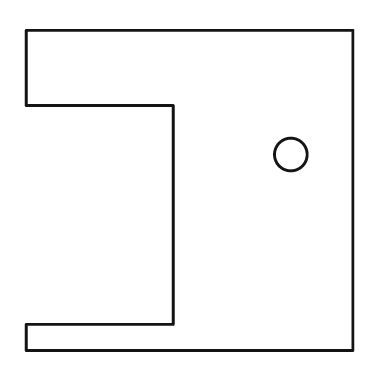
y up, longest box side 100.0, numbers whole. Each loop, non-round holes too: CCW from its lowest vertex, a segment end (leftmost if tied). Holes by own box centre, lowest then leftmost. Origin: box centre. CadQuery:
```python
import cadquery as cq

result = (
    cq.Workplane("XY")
    .moveTo(-50.0, -49.0)
    .lineTo(50.0, -49.0)
    .lineTo(50.0, 49.0)
    .lineTo(-50.0, 49.0)
    .lineTo(-50.0, 26.0)
    .lineTo(-5.0, 26.0)
    .lineTo(-5.0, -41.0)
    .lineTo(-50.0, -41.0)
    .close()
    .moveTo(31.0, 11.0)
    .circle(5.0)
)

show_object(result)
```